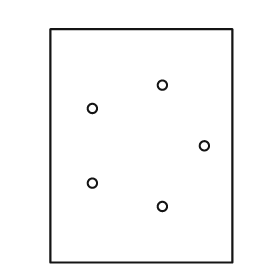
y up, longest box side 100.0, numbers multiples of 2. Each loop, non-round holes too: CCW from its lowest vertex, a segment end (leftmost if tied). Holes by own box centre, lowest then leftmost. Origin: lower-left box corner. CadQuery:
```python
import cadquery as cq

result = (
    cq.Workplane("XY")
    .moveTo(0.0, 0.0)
    .lineTo(78.0, 0.0)
    .lineTo(78.0, 100.0)
    .lineTo(0.0, 100.0)
    .close()
    .moveTo(48.0, 24.0)
    .circle(2.0)
    .moveTo(18.0, 34.0)
    .circle(2.0)
    .moveTo(66.0, 50.0)
    .circle(2.0)
    .moveTo(18.0, 66.0)
    .circle(2.0)
    .moveTo(48.0, 76.0)
    .circle(2.0)
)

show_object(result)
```